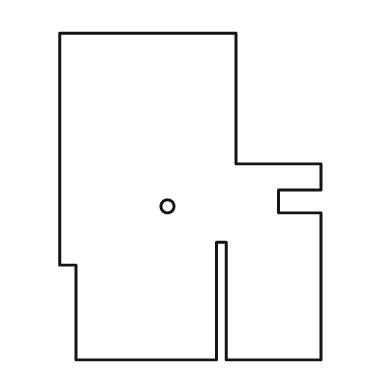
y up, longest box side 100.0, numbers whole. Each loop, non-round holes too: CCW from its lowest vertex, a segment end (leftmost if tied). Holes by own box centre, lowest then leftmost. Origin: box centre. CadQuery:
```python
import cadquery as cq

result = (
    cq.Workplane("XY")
    .moveTo(-35.0, -50.0)
    .lineTo(8.0, -50.0)
    .lineTo(8.0, -14.0)
    .lineTo(11.0, -14.0)
    .lineTo(11.0, -50.0)
    .lineTo(40.0, -50.0)
    .lineTo(40.0, -5.0)
    .lineTo(27.0, -5.0)
    .lineTo(27.0, 2.0)
    .lineTo(40.0, 2.0)
    .lineTo(40.0, 10.0)
    .lineTo(14.0, 10.0)
    .lineTo(14.0, 50.0)
    .lineTo(-40.0, 50.0)
    .lineTo(-40.0, -21.0)
    .lineTo(-35.0, -21.0)
    .close()
    .moveTo(-7.0, -3.0)
    .circle(2.0)
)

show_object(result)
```